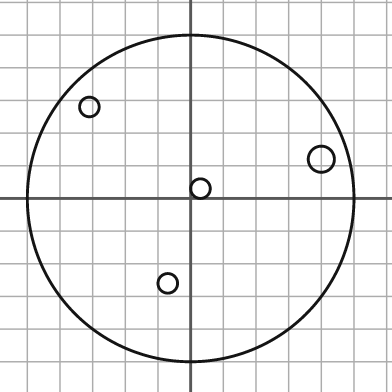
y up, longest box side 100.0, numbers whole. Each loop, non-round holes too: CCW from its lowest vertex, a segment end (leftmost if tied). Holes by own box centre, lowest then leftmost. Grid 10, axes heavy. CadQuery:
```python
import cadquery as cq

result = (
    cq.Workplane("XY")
    .moveTo(0.0, 0.0)
    .circle(50.0)
    .moveTo(-7.0, -26.0)
    .circle(3.0)
    .moveTo(3.0, 3.0)
    .circle(3.0)
    .moveTo(40.0, 12.0)
    .circle(4.0)
    .moveTo(-31.0, 28.0)
    .circle(3.0)
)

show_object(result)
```